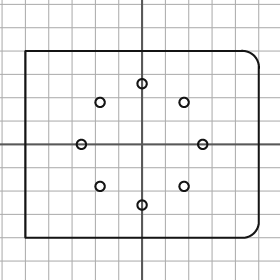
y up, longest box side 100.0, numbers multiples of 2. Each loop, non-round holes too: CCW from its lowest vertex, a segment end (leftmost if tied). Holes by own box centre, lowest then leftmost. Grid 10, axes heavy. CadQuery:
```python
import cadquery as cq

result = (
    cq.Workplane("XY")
    .moveTo(-50.0, -40.0)
    .lineTo(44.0, -40.0)
    .threePointArc((48.0, -38.0), (50.0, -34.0))
    .lineTo(50.0, 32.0)
    .threePointArc((48.0, 38.0), (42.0, 40.0))
    .lineTo(-50.0, 40.0)
    .close()
    .moveTo(0.0, -26.0)
    .circle(2.0)
    .moveTo(-18.0, -18.0)
    .circle(2.0)
    .moveTo(18.0, -18.0)
    .circle(2.0)
    .moveTo(-26.0, 0.0)
    .circle(2.0)
    .moveTo(26.0, 0.0)
    .circle(2.0)
    .moveTo(-18.0, 18.0)
    .circle(2.0)
    .moveTo(18.0, 18.0)
    .circle(2.0)
    .moveTo(0.0, 26.0)
    .circle(2.0)
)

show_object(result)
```